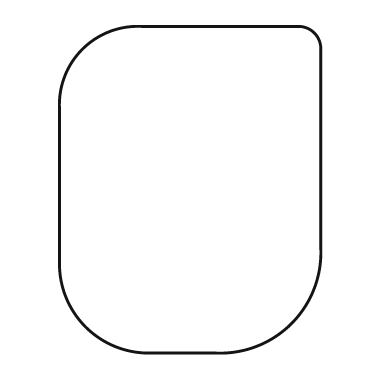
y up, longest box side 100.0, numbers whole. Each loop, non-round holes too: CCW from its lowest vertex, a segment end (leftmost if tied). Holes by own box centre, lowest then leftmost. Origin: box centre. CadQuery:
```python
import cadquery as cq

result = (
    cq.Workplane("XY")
    .moveTo(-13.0, -50.0)
    .lineTo(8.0, -50.0)
    .threePointArc((31.0, -41.0), (40.0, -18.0))
    .lineTo(40.0, 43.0)
    .threePointArc((38.0, 48.0), (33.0, 50.0))
    .lineTo(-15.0, 50.0)
    .threePointArc((-33.0, 43.0), (-40.0, 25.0))
    .lineTo(-40.0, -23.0)
    .threePointArc((-32.0, -42.0), (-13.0, -50.0))
    .close()
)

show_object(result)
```